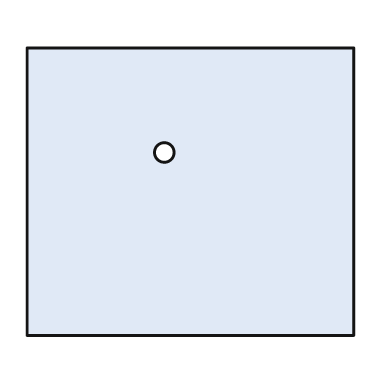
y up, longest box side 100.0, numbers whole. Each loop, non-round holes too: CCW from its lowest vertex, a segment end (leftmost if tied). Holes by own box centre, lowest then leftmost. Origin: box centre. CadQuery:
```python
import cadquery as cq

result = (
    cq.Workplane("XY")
    .moveTo(-50.0, -44.0)
    .lineTo(50.0, -44.0)
    .lineTo(50.0, 44.0)
    .lineTo(-50.0, 44.0)
    .close()
    .moveTo(-8.0, 12.0)
    .circle(3.0)
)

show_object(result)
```